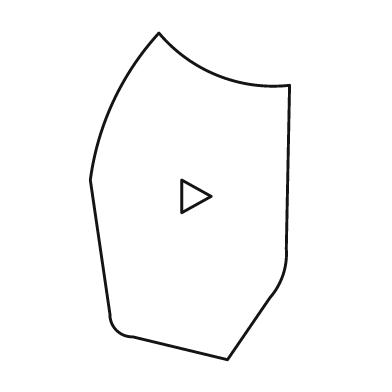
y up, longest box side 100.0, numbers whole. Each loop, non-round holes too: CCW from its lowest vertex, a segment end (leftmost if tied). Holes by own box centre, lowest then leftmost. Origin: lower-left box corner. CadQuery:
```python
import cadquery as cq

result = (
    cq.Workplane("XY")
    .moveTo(42.0, 0.0)
    .lineTo(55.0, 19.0)
    .threePointArc((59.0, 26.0), (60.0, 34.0))
    .lineTo(61.0, 84.0)
    .threePointArc((39.0, 87.0), (21.0, 100.0))
    .threePointArc((7.0, 79.0), (0.0, 55.0))
    .lineTo(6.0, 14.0)
    .threePointArc((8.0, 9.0), (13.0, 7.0))
    .close()
    .moveTo(28.0, 45.0)
    .lineTo(37.0, 50.0)
    .lineTo(28.0, 55.0)
    .close()
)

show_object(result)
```